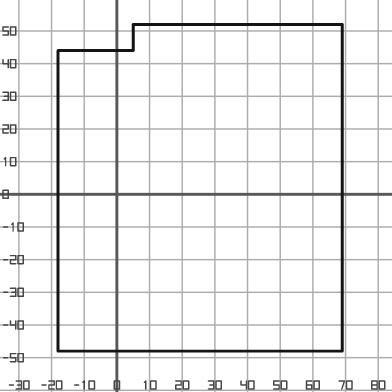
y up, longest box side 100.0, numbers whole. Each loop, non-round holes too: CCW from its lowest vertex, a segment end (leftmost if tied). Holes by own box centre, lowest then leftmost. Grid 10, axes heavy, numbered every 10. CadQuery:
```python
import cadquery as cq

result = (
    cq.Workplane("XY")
    .moveTo(-18.0, -48.0)
    .lineTo(69.0, -48.0)
    .lineTo(69.0, 52.0)
    .lineTo(5.0, 52.0)
    .lineTo(5.0, 44.0)
    .lineTo(-18.0, 44.0)
    .close()
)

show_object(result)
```